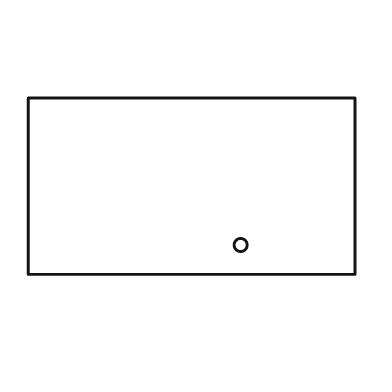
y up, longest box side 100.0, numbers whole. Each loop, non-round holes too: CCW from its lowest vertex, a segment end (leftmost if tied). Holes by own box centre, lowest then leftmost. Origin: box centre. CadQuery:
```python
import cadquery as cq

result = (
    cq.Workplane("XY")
    .moveTo(-50.0, -27.0)
    .lineTo(50.0, -27.0)
    .lineTo(50.0, 27.0)
    .lineTo(-50.0, 27.0)
    .close()
    .moveTo(15.0, -18.0)
    .circle(2.0)
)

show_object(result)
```